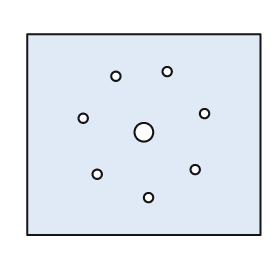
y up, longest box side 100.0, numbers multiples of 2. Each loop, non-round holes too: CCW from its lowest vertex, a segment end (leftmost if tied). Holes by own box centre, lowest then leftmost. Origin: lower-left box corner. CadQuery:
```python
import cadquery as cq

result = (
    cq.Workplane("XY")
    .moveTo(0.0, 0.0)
    .lineTo(100.0, 0.0)
    .lineTo(100.0, 86.0)
    .lineTo(0.0, 86.0)
    .close()
    .moveTo(52.0, 16.0)
    .circle(2.0)
    .moveTo(30.0, 26.0)
    .circle(2.0)
    .moveTo(72.0, 28.0)
    .circle(2.0)
    .moveTo(50.0, 44.0)
    .circle(4.0)
    .moveTo(24.0, 50.0)
    .circle(2.0)
    .moveTo(76.0, 52.0)
    .circle(2.0)
    .moveTo(38.0, 68.0)
    .circle(2.0)
    .moveTo(60.0, 70.0)
    .circle(2.0)
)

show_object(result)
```